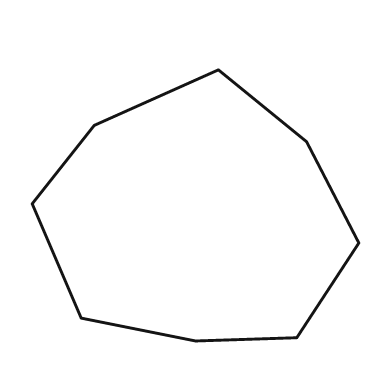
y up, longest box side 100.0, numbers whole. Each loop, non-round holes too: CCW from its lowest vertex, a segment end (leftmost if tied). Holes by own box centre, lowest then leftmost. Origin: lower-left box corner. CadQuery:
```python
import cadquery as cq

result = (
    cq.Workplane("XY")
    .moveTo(50.0, 0.0)
    .lineTo(81.0, 1.0)
    .lineTo(100.0, 30.0)
    .lineTo(84.0, 61.0)
    .lineTo(57.0, 83.0)
    .lineTo(19.0, 66.0)
    .lineTo(0.0, 42.0)
    .lineTo(15.0, 7.0)
    .close()
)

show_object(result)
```